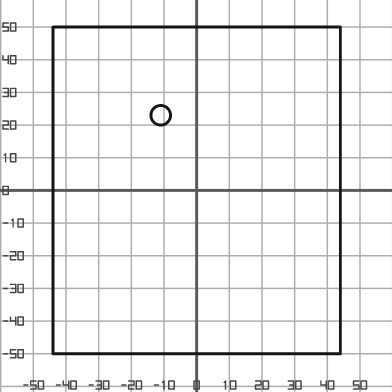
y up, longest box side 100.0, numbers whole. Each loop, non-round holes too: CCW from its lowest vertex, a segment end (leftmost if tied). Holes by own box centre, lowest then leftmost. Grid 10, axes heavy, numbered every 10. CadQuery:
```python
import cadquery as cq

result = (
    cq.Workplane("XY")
    .moveTo(-44.0, -50.0)
    .lineTo(44.0, -50.0)
    .lineTo(44.0, 50.0)
    .lineTo(-44.0, 50.0)
    .close()
    .moveTo(-11.0, 23.0)
    .circle(3.0)
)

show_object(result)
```